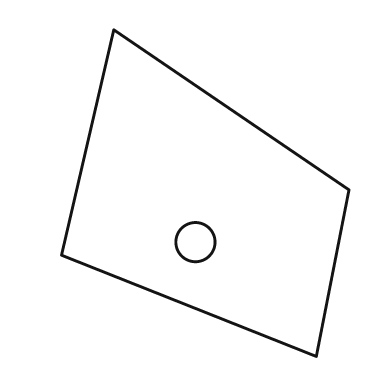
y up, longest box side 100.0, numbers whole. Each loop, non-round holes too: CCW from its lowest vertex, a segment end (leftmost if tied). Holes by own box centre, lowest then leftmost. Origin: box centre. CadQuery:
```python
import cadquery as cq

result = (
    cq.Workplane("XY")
    .moveTo(34.0, -50.0)
    .lineTo(44.0, 1.0)
    .lineTo(-28.0, 50.0)
    .lineTo(-44.0, -19.0)
    .close()
    .moveTo(-3.0, -15.0)
    .circle(6.0)
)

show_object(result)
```